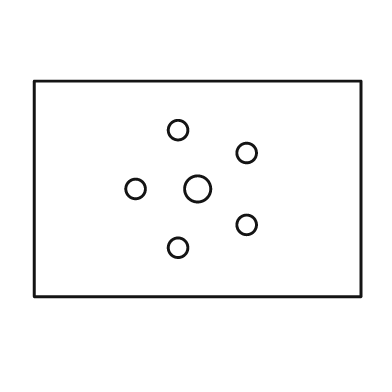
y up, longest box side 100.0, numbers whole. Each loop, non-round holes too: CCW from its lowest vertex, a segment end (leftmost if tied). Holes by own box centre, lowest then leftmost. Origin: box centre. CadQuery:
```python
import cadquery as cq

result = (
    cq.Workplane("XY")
    .moveTo(-50.0, -33.0)
    .lineTo(50.0, -33.0)
    .lineTo(50.0, 33.0)
    .lineTo(-50.0, 33.0)
    .close()
    .moveTo(-6.0, -18.0)
    .circle(3.0)
    .moveTo(15.0, -11.0)
    .circle(3.0)
    .moveTo(-19.0, 0.0)
    .circle(3.0)
    .moveTo(0.0, 0.0)
    .circle(4.0)
    .moveTo(15.0, 11.0)
    .circle(3.0)
    .moveTo(-6.0, 18.0)
    .circle(3.0)
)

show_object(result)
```